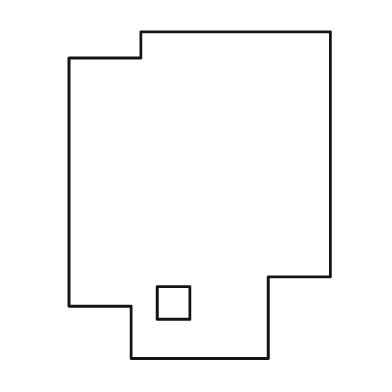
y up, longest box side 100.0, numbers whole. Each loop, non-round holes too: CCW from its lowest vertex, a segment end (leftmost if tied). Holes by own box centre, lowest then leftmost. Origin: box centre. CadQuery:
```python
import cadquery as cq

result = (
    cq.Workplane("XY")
    .moveTo(-21.0, -50.0)
    .lineTo(21.0, -50.0)
    .lineTo(21.0, -25.0)
    .lineTo(40.0, -25.0)
    .lineTo(40.0, 50.0)
    .lineTo(-18.0, 50.0)
    .lineTo(-18.0, 42.0)
    .lineTo(-40.0, 42.0)
    .lineTo(-40.0, -34.0)
    .lineTo(-21.0, -34.0)
    .close()
    .moveTo(-13.0, -38.0)
    .lineTo(-3.0, -38.0)
    .lineTo(-3.0, -28.0)
    .lineTo(-13.0, -28.0)
    .close()
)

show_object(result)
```